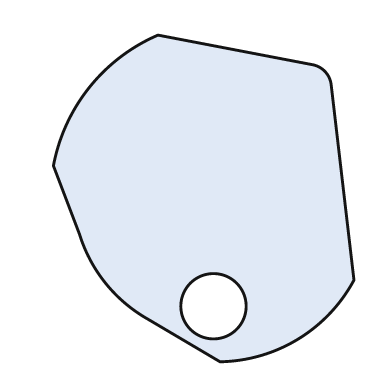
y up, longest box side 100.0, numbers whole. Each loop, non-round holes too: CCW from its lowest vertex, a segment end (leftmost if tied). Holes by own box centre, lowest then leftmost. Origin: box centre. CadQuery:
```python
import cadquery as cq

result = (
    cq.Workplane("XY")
    .moveTo(5.0, -50.0)
    .threePointArc((29.0, -43.0), (46.0, -25.0))
    .lineTo(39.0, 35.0)
    .threePointArc((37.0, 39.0), (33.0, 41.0))
    .lineTo(-14.0, 50.0)
    .threePointArc((-35.0, 34.0), (-46.0, 10.0))
    .lineTo(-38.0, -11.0)
    .threePointArc((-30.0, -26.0), (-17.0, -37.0))
    .close()
    .moveTo(3.0, -33.0)
    .circle(10.0)
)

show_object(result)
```